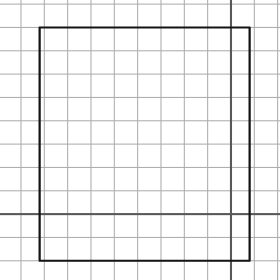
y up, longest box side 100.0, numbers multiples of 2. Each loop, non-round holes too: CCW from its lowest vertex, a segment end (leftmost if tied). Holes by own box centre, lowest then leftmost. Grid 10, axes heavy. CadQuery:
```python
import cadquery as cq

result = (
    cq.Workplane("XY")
    .moveTo(-82.0, -20.0)
    .lineTo(8.0, -20.0)
    .lineTo(8.0, 80.0)
    .lineTo(-82.0, 80.0)
    .close()
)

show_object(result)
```